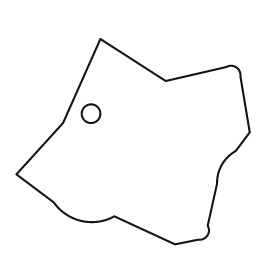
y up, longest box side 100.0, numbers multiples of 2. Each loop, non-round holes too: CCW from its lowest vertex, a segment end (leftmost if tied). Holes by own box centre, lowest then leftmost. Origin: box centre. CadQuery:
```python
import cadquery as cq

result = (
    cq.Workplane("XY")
    .moveTo(18.0, -44.0)
    .lineTo(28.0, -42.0)
    .threePointArc((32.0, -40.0), (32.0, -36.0))
    .lineTo(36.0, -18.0)
    .threePointArc((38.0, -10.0), (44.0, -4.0))
    .lineTo(50.0, 4.0)
    .lineTo(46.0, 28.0)
    .threePointArc((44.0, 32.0), (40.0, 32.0))
    .lineTo(14.0, 26.0)
    .lineTo(-14.0, 44.0)
    .lineTo(-30.0, 8.0)
    .lineTo(-50.0, -14.0)
    .lineTo(-34.0, -26.0)
    .threePointArc((-22.0, -34.0), (-8.0, -32.0))
    .close()
    .moveTo(-18.0, 12.0)
    .circle(4.0)
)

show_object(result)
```